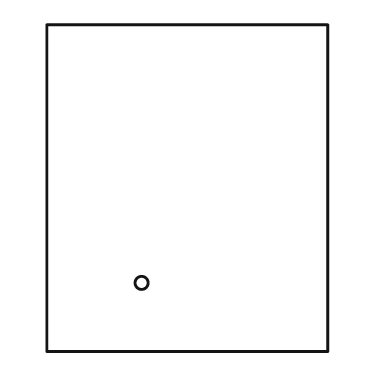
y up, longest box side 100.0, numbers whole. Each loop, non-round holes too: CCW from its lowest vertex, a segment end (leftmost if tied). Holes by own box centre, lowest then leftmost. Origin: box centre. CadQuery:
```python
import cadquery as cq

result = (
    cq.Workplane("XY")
    .moveTo(-43.0, -50.0)
    .lineTo(43.0, -50.0)
    .lineTo(43.0, 50.0)
    .lineTo(-43.0, 50.0)
    .close()
    .moveTo(-14.0, -29.0)
    .circle(2.0)
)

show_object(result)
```